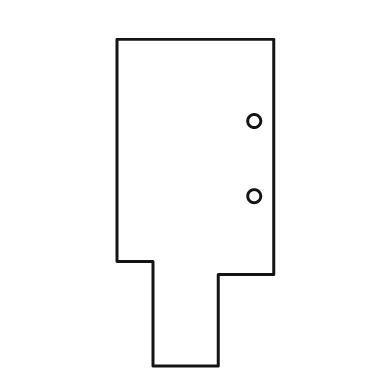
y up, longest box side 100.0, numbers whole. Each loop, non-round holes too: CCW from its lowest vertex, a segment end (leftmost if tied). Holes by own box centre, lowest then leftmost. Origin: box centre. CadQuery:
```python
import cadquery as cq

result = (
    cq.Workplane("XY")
    .moveTo(-13.0, -50.0)
    .lineTo(7.0, -50.0)
    .lineTo(7.0, -22.0)
    .lineTo(24.0, -22.0)
    .lineTo(24.0, 50.0)
    .lineTo(-24.0, 50.0)
    .lineTo(-24.0, -18.0)
    .lineTo(-13.0, -18.0)
    .close()
    .moveTo(18.0, 2.0)
    .circle(2.0)
    .moveTo(18.0, 25.0)
    .circle(2.0)
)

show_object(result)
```